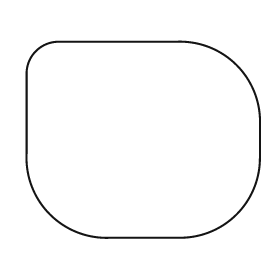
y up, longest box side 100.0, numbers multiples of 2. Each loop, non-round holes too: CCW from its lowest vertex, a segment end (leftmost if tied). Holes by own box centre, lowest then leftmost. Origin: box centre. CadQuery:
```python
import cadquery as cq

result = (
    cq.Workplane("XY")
    .moveTo(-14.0, -42.0)
    .lineTo(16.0, -42.0)
    .threePointArc((40.0, -32.0), (50.0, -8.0))
    .lineTo(50.0, 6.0)
    .threePointArc((40.0, 32.0), (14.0, 42.0))
    .lineTo(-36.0, 42.0)
    .threePointArc((-46.0, 38.0), (-50.0, 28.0))
    .lineTo(-50.0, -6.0)
    .threePointArc((-40.0, -32.0), (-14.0, -42.0))
    .close()
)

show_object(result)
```